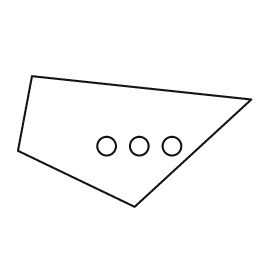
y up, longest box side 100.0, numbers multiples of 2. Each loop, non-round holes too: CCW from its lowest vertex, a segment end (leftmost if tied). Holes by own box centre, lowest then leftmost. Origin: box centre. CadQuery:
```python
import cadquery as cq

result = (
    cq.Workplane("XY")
    .moveTo(0.0, -28.0)
    .lineTo(50.0, 18.0)
    .lineTo(-44.0, 28.0)
    .lineTo(-50.0, -4.0)
    .close()
    .moveTo(-12.0, -2.0)
    .circle(4.0)
    .moveTo(2.0, -2.0)
    .circle(4.0)
    .moveTo(16.0, -2.0)
    .circle(4.0)
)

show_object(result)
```